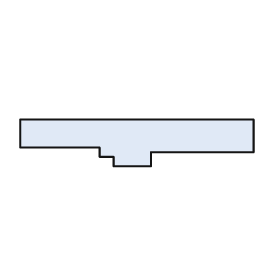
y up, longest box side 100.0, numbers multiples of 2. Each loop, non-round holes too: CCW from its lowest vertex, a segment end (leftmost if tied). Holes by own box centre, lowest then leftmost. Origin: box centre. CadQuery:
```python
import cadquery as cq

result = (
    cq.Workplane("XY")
    .moveTo(-10.0, -10.0)
    .lineTo(6.0, -10.0)
    .lineTo(6.0, -4.0)
    .lineTo(50.0, -4.0)
    .lineTo(50.0, 10.0)
    .lineTo(-50.0, 10.0)
    .lineTo(-50.0, -2.0)
    .lineTo(-16.0, -2.0)
    .lineTo(-16.0, -6.0)
    .lineTo(-10.0, -6.0)
    .close()
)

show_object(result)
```